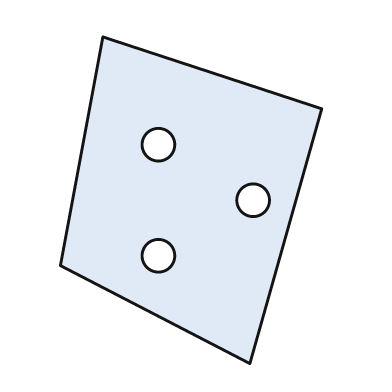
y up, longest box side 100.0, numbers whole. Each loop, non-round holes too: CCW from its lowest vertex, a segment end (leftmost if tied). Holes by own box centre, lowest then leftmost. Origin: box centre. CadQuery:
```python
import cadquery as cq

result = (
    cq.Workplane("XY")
    .moveTo(18.0, -50.0)
    .lineTo(40.0, 28.0)
    .lineTo(-27.0, 50.0)
    .lineTo(-40.0, -20.0)
    .close()
    .moveTo(-10.0, -17.0)
    .circle(5.0)
    .moveTo(19.0, 0.0)
    .circle(5.0)
    .moveTo(-10.0, 17.0)
    .circle(5.0)
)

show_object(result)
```